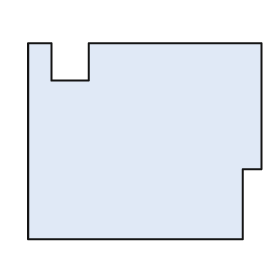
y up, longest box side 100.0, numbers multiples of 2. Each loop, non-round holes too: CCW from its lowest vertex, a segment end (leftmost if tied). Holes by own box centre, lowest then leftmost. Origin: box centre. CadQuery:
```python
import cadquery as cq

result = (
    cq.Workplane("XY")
    .moveTo(-50.0, -42.0)
    .lineTo(42.0, -42.0)
    .lineTo(42.0, -12.0)
    .lineTo(50.0, -12.0)
    .lineTo(50.0, 42.0)
    .lineTo(-24.0, 42.0)
    .lineTo(-24.0, 26.0)
    .lineTo(-40.0, 26.0)
    .lineTo(-40.0, 42.0)
    .lineTo(-50.0, 42.0)
    .close()
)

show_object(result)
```